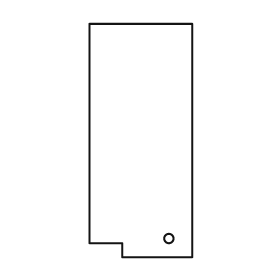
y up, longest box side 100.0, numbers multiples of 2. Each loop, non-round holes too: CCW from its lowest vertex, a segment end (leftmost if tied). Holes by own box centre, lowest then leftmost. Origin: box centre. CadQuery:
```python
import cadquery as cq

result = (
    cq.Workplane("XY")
    .moveTo(-8.0, -50.0)
    .lineTo(22.0, -50.0)
    .lineTo(22.0, 50.0)
    .lineTo(-22.0, 50.0)
    .lineTo(-22.0, -44.0)
    .lineTo(-8.0, -44.0)
    .close()
    .moveTo(12.0, -42.0)
    .circle(2.0)
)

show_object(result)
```